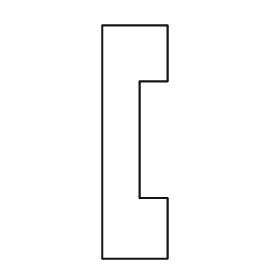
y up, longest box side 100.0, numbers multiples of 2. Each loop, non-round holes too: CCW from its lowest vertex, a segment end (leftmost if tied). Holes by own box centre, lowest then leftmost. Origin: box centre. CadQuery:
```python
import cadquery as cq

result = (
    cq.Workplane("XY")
    .moveTo(-14.0, -50.0)
    .lineTo(14.0, -50.0)
    .lineTo(14.0, -24.0)
    .lineTo(2.0, -24.0)
    .lineTo(2.0, 26.0)
    .lineTo(14.0, 26.0)
    .lineTo(14.0, 50.0)
    .lineTo(-14.0, 50.0)
    .close()
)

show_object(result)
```